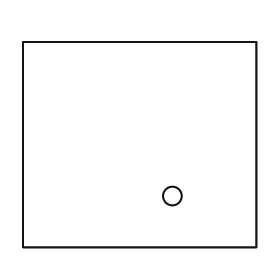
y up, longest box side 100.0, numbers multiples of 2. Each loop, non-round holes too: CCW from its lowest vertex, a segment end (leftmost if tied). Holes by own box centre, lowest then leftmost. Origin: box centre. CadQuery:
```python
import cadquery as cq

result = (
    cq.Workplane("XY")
    .moveTo(-50.0, -44.0)
    .lineTo(50.0, -44.0)
    .lineTo(50.0, 44.0)
    .lineTo(-50.0, 44.0)
    .close()
    .moveTo(14.0, -22.0)
    .circle(4.0)
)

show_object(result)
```